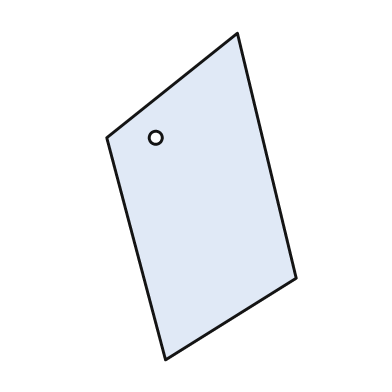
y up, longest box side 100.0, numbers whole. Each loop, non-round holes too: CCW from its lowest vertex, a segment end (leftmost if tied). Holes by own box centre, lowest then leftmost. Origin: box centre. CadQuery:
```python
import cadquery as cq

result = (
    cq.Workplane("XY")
    .moveTo(-11.0, -50.0)
    .lineTo(29.0, -25.0)
    .lineTo(11.0, 50.0)
    .lineTo(-29.0, 18.0)
    .close()
    .moveTo(-14.0, 18.0)
    .circle(2.0)
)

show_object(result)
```